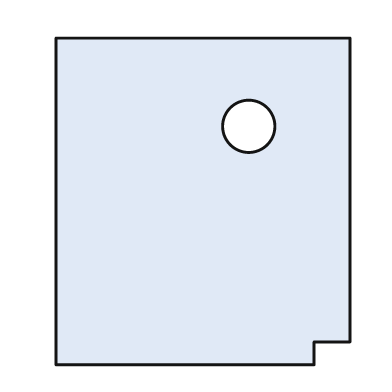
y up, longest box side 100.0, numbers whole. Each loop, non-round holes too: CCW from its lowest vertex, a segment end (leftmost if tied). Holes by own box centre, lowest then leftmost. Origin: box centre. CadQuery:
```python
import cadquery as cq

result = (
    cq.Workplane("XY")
    .moveTo(-45.0, -50.0)
    .lineTo(34.0, -50.0)
    .lineTo(34.0, -43.0)
    .lineTo(45.0, -43.0)
    .lineTo(45.0, 50.0)
    .lineTo(-45.0, 50.0)
    .close()
    .moveTo(14.0, 23.0)
    .circle(8.0)
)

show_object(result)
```